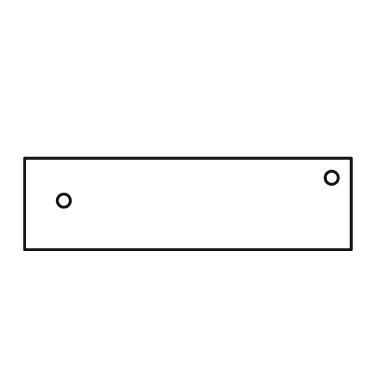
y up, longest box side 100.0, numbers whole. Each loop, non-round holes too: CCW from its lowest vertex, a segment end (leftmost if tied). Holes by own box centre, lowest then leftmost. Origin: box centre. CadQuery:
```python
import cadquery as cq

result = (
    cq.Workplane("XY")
    .moveTo(-50.0, -14.0)
    .lineTo(50.0, -14.0)
    .lineTo(50.0, 14.0)
    .lineTo(-50.0, 14.0)
    .close()
    .moveTo(-38.0, 1.0)
    .circle(2.0)
    .moveTo(44.0, 8.0)
    .circle(2.0)
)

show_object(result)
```